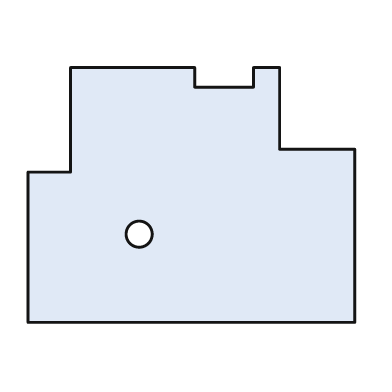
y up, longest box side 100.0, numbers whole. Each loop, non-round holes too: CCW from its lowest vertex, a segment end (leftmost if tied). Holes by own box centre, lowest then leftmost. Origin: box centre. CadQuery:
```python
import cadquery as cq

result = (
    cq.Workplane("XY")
    .moveTo(-50.0, -39.0)
    .lineTo(50.0, -39.0)
    .lineTo(50.0, 14.0)
    .lineTo(27.0, 14.0)
    .lineTo(27.0, 39.0)
    .lineTo(19.0, 39.0)
    .lineTo(19.0, 33.0)
    .lineTo(1.0, 33.0)
    .lineTo(1.0, 39.0)
    .lineTo(-37.0, 39.0)
    .lineTo(-37.0, 7.0)
    .lineTo(-50.0, 7.0)
    .close()
    .moveTo(-16.0, -12.0)
    .circle(4.0)
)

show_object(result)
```